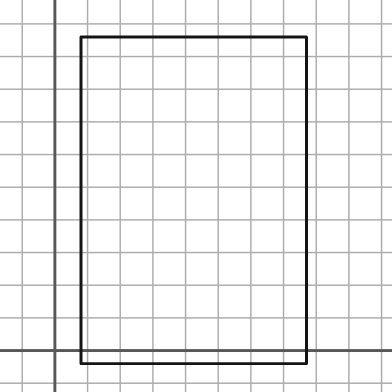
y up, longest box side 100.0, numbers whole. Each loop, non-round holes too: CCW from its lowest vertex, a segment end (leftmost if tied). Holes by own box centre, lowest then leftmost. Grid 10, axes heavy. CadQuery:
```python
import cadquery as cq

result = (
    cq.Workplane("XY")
    .moveTo(8.0, -4.0)
    .lineTo(77.0, -4.0)
    .lineTo(77.0, 96.0)
    .lineTo(8.0, 96.0)
    .close()
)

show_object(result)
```